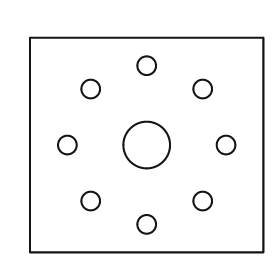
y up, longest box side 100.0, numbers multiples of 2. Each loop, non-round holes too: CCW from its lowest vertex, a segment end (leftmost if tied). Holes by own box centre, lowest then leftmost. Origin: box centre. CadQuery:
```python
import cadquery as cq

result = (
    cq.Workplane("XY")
    .moveTo(-50.0, -46.0)
    .lineTo(50.0, -46.0)
    .lineTo(50.0, 46.0)
    .lineTo(-50.0, 46.0)
    .close()
    .moveTo(0.0, -34.0)
    .circle(4.0)
    .moveTo(-24.0, -24.0)
    .circle(4.0)
    .moveTo(24.0, -24.0)
    .circle(4.0)
    .moveTo(-34.0, 0.0)
    .circle(4.0)
    .moveTo(0.0, 0.0)
    .circle(10.0)
    .moveTo(34.0, 0.0)
    .circle(4.0)
    .moveTo(-24.0, 24.0)
    .circle(4.0)
    .moveTo(24.0, 24.0)
    .circle(4.0)
    .moveTo(0.0, 34.0)
    .circle(4.0)
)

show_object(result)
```